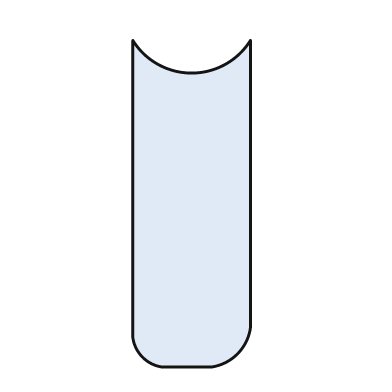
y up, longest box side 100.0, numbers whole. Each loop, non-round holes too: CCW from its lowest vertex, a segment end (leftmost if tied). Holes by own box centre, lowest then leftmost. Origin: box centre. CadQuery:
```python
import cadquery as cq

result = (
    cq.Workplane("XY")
    .moveTo(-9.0, -50.0)
    .lineTo(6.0, -50.0)
    .threePointArc((14.0, -46.0), (18.0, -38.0))
    .lineTo(18.0, 50.0)
    .threePointArc((0.0, 40.0), (-18.0, 50.0))
    .lineTo(-18.0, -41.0)
    .threePointArc((-15.0, -47.0), (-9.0, -50.0))
    .close()
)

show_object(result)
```